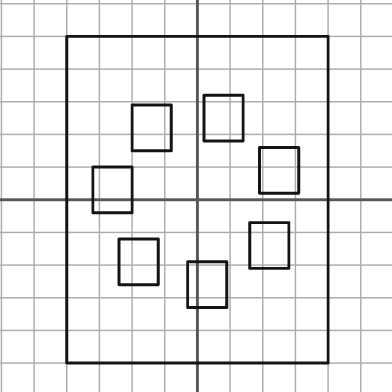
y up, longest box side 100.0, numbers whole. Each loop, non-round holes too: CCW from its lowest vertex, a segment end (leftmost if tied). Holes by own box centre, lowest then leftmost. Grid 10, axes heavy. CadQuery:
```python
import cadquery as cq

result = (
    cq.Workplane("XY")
    .moveTo(-40.0, -50.0)
    .lineTo(40.0, -50.0)
    .lineTo(40.0, 50.0)
    .lineTo(-40.0, 50.0)
    .close()
    .moveTo(-3.0, -33.0)
    .lineTo(9.0, -33.0)
    .lineTo(9.0, -19.0)
    .lineTo(-3.0, -19.0)
    .close()
    .moveTo(-24.0, -26.0)
    .lineTo(-12.0, -26.0)
    .lineTo(-12.0, -12.0)
    .lineTo(-24.0, -12.0)
    .close()
    .moveTo(16.0, -21.0)
    .lineTo(28.0, -21.0)
    .lineTo(28.0, -7.0)
    .lineTo(16.0, -7.0)
    .close()
    .moveTo(-32.0, -4.0)
    .lineTo(-20.0, -4.0)
    .lineTo(-20.0, 10.0)
    .lineTo(-32.0, 10.0)
    .close()
    .moveTo(19.0, 2.0)
    .lineTo(31.0, 2.0)
    .lineTo(31.0, 16.0)
    .lineTo(19.0, 16.0)
    .close()
    .moveTo(-20.0, 15.0)
    .lineTo(-8.0, 15.0)
    .lineTo(-8.0, 29.0)
    .lineTo(-20.0, 29.0)
    .close()
    .moveTo(2.0, 18.0)
    .lineTo(14.0, 18.0)
    .lineTo(14.0, 32.0)
    .lineTo(2.0, 32.0)
    .close()
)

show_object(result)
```